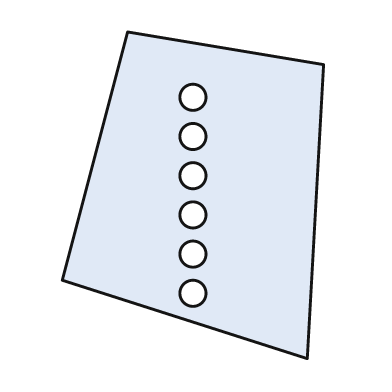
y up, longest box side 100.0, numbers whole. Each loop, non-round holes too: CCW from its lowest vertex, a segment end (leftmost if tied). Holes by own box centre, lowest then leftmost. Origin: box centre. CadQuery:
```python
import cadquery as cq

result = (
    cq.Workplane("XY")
    .moveTo(35.0, -50.0)
    .lineTo(40.0, 40.0)
    .lineTo(-20.0, 50.0)
    .lineTo(-40.0, -26.0)
    .close()
    .moveTo(0.0, -30.0)
    .circle(4.0)
    .moveTo(0.0, -18.0)
    .circle(4.0)
    .moveTo(0.0, -6.0)
    .circle(4.0)
    .moveTo(0.0, 6.0)
    .circle(4.0)
    .moveTo(0.0, 18.0)
    .circle(4.0)
    .moveTo(0.0, 30.0)
    .circle(4.0)
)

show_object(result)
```